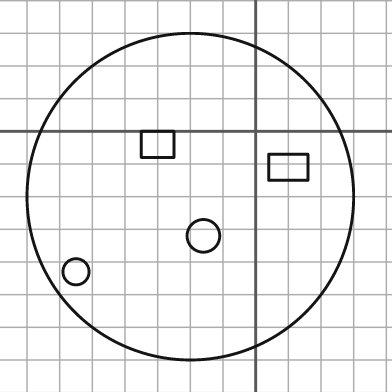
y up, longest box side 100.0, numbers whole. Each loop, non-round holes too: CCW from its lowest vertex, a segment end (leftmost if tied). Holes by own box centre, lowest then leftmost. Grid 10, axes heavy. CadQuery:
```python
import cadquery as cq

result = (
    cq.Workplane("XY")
    .moveTo(-20.0, -20.0)
    .circle(50.0)
    .moveTo(-55.0, -43.0)
    .circle(4.0)
    .moveTo(-16.0, -32.0)
    .circle(5.0)
    .moveTo(4.0, -15.0)
    .lineTo(16.0, -15.0)
    .lineTo(16.0, -7.0)
    .lineTo(4.0, -7.0)
    .close()
    .moveTo(-35.0, -8.0)
    .lineTo(-25.0, -8.0)
    .lineTo(-25.0, 0.0)
    .lineTo(-35.0, 0.0)
    .close()
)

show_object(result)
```